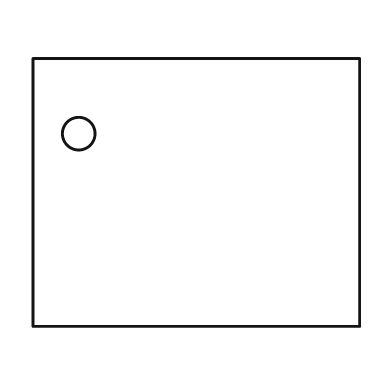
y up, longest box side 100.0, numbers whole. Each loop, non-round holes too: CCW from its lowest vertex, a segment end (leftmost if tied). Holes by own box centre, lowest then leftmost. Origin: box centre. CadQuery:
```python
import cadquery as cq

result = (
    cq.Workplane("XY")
    .moveTo(-50.0, -41.0)
    .lineTo(50.0, -41.0)
    .lineTo(50.0, 41.0)
    .lineTo(-50.0, 41.0)
    .close()
    .moveTo(-36.0, 18.0)
    .circle(5.0)
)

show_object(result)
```